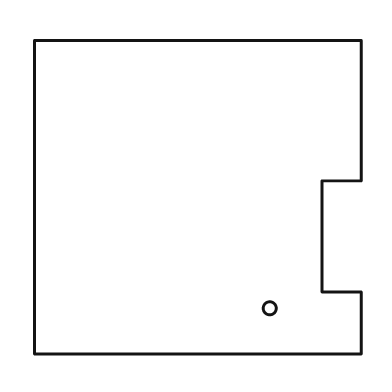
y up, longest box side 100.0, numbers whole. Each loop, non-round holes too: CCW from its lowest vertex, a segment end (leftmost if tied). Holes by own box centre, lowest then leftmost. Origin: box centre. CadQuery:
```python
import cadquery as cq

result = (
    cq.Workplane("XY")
    .moveTo(-50.0, -48.0)
    .lineTo(50.0, -48.0)
    .lineTo(50.0, -29.0)
    .lineTo(38.0, -29.0)
    .lineTo(38.0, 5.0)
    .lineTo(50.0, 5.0)
    .lineTo(50.0, 48.0)
    .lineTo(-50.0, 48.0)
    .close()
    .moveTo(22.0, -34.0)
    .circle(2.0)
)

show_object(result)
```